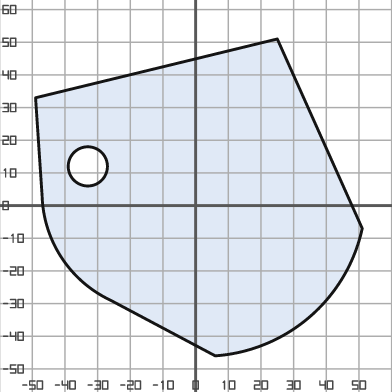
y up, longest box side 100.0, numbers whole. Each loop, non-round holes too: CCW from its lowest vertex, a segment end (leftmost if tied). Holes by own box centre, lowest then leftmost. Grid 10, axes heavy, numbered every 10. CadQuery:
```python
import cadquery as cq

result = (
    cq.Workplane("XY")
    .moveTo(6.0, -46.0)
    .threePointArc((35.0, -34.0), (51.0, -7.0))
    .lineTo(25.0, 51.0)
    .lineTo(-49.0, 33.0)
    .lineTo(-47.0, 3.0)
    .threePointArc((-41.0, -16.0), (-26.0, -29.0))
    .close()
    .moveTo(-33.0, 12.0)
    .circle(6.0)
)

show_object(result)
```